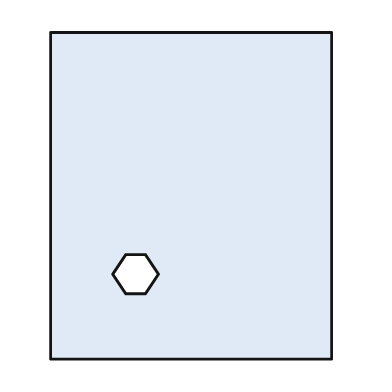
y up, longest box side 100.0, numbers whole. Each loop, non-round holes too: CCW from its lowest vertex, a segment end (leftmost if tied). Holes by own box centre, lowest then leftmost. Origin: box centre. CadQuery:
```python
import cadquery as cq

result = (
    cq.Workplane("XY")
    .moveTo(-43.0, -50.0)
    .lineTo(43.0, -50.0)
    .lineTo(43.0, 50.0)
    .lineTo(-43.0, 50.0)
    .close()
    .moveTo(-20.0, -30.0)
    .lineTo(-14.0, -30.0)
    .lineTo(-10.0, -24.0)
    .lineTo(-14.0, -18.0)
    .lineTo(-20.0, -18.0)
    .lineTo(-24.0, -24.0)
    .close()
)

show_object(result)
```